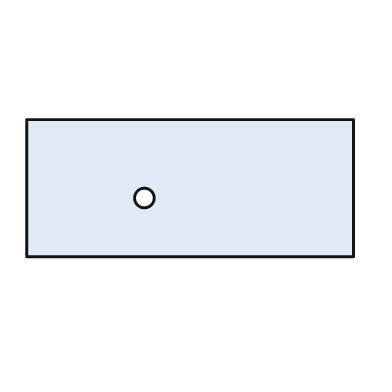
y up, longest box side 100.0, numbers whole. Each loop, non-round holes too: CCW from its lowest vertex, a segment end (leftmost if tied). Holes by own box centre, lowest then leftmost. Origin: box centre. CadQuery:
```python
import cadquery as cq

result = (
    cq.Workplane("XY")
    .moveTo(-50.0, -21.0)
    .lineTo(50.0, -21.0)
    .lineTo(50.0, 21.0)
    .lineTo(-50.0, 21.0)
    .close()
    .moveTo(-14.0, -3.0)
    .circle(3.0)
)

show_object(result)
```